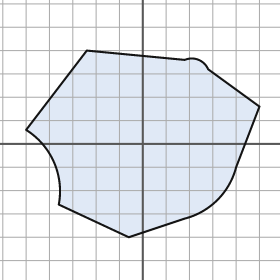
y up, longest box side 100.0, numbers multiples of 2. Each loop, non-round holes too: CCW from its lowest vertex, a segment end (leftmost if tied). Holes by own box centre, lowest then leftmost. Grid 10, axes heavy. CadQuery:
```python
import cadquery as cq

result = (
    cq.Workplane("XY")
    .moveTo(-6.0, -40.0)
    .lineTo(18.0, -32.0)
    .threePointArc((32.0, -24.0), (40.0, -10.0))
    .lineTo(50.0, 16.0)
    .lineTo(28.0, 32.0)
    .threePointArc((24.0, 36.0), (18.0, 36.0))
    .lineTo(-24.0, 40.0)
    .lineTo(-50.0, 6.0)
    .threePointArc((-38.0, -8.0), (-36.0, -26.0))
    .close()
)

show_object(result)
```